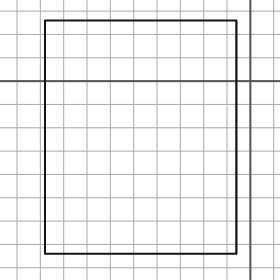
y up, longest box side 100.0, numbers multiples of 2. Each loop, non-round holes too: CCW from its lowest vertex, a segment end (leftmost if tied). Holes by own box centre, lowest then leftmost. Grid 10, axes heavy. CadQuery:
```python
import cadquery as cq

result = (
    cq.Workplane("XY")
    .moveTo(-88.0, -74.0)
    .lineTo(-6.0, -74.0)
    .lineTo(-6.0, 26.0)
    .lineTo(-88.0, 26.0)
    .close()
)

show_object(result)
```